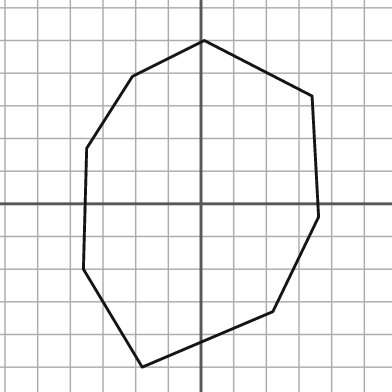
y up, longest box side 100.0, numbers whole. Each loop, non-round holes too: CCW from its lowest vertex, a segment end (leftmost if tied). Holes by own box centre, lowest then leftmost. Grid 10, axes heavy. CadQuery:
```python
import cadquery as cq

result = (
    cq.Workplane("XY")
    .moveTo(-18.0, -50.0)
    .lineTo(22.0, -33.0)
    .lineTo(36.0, -4.0)
    .lineTo(34.0, 33.0)
    .lineTo(1.0, 50.0)
    .lineTo(-21.0, 39.0)
    .lineTo(-35.0, 17.0)
    .lineTo(-36.0, -20.0)
    .close()
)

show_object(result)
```